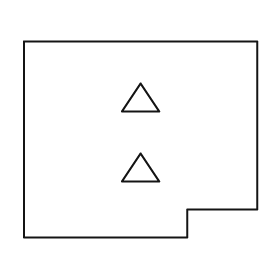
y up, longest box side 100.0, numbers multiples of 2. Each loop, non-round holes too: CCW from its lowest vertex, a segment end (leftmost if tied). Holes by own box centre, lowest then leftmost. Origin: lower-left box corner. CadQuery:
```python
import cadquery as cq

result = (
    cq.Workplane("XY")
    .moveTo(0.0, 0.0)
    .lineTo(70.0, 0.0)
    .lineTo(70.0, 12.0)
    .lineTo(100.0, 12.0)
    .lineTo(100.0, 84.0)
    .lineTo(0.0, 84.0)
    .close()
    .moveTo(42.0, 24.0)
    .lineTo(58.0, 24.0)
    .lineTo(50.0, 36.0)
    .close()
    .moveTo(42.0, 54.0)
    .lineTo(58.0, 54.0)
    .lineTo(50.0, 66.0)
    .close()
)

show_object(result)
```